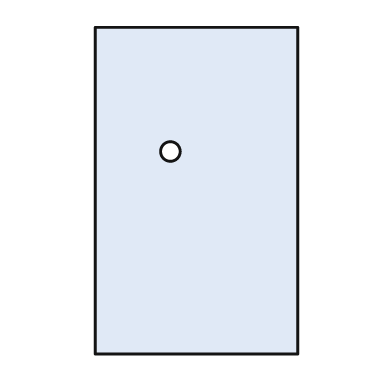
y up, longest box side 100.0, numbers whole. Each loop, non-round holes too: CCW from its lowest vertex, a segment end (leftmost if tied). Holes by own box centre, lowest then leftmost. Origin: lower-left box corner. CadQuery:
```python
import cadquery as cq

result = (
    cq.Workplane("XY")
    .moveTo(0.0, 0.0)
    .lineTo(62.0, 0.0)
    .lineTo(62.0, 100.0)
    .lineTo(0.0, 100.0)
    .close()
    .moveTo(23.0, 62.0)
    .circle(3.0)
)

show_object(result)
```